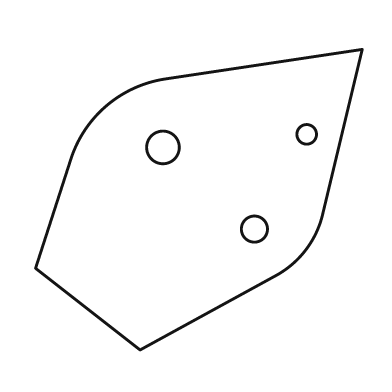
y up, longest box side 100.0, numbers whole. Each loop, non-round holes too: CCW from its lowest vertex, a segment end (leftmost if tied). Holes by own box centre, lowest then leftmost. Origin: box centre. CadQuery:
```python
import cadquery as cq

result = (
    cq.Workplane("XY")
    .moveTo(-18.0, -46.0)
    .lineTo(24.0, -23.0)
    .threePointArc((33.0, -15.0), (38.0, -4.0))
    .lineTo(50.0, 46.0)
    .lineTo(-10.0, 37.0)
    .threePointArc((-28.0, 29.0), (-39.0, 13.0))
    .lineTo(-50.0, -21.0)
    .close()
    .moveTo(17.0, -9.0)
    .circle(4.0)
    .moveTo(-11.0, 16.0)
    .circle(5.0)
    .moveTo(33.0, 20.0)
    .circle(3.0)
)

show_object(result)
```